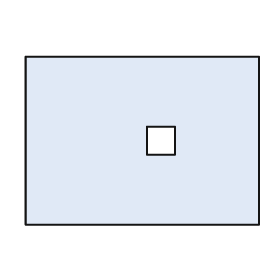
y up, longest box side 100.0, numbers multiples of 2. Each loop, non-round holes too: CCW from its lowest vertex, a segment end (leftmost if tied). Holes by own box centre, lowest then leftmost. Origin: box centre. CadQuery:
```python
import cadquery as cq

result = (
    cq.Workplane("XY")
    .moveTo(-50.0, -36.0)
    .lineTo(50.0, -36.0)
    .lineTo(50.0, 36.0)
    .lineTo(-50.0, 36.0)
    .close()
    .moveTo(2.0, -6.0)
    .lineTo(14.0, -6.0)
    .lineTo(14.0, 6.0)
    .lineTo(2.0, 6.0)
    .close()
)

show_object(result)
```